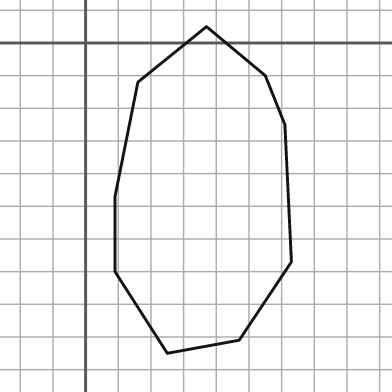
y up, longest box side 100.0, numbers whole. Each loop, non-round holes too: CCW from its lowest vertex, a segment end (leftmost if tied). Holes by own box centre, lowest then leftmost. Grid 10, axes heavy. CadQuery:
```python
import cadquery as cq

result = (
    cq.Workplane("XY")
    .moveTo(25.0, -95.0)
    .lineTo(47.0, -91.0)
    .lineTo(63.0, -67.0)
    .lineTo(61.0, -25.0)
    .lineTo(55.0, -10.0)
    .lineTo(37.0, 5.0)
    .lineTo(16.0, -12.0)
    .lineTo(9.0, -47.0)
    .lineTo(9.0, -70.0)
    .close()
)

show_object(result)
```